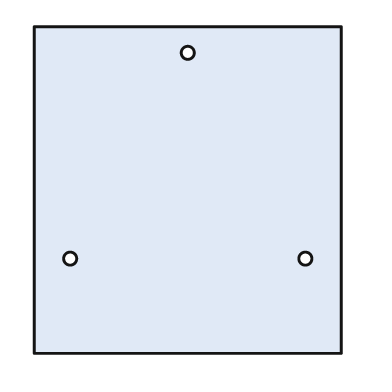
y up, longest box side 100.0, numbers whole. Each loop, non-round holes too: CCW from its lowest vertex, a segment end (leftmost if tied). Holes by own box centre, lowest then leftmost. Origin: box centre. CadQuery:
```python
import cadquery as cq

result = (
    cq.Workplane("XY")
    .moveTo(-47.0, -50.0)
    .lineTo(47.0, -50.0)
    .lineTo(47.0, 50.0)
    .lineTo(-47.0, 50.0)
    .close()
    .moveTo(-36.0, -21.0)
    .circle(2.0)
    .moveTo(36.0, -21.0)
    .circle(2.0)
    .moveTo(0.0, 42.0)
    .circle(2.0)
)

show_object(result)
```